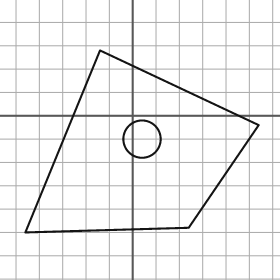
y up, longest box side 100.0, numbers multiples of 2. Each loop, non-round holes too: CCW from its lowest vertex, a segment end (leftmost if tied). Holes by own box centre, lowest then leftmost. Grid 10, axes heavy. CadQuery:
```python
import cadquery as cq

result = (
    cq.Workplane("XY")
    .moveTo(-46.0, -50.0)
    .lineTo(24.0, -48.0)
    .lineTo(54.0, -4.0)
    .lineTo(-14.0, 28.0)
    .close()
    .moveTo(4.0, -10.0)
    .circle(8.0)
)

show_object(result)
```